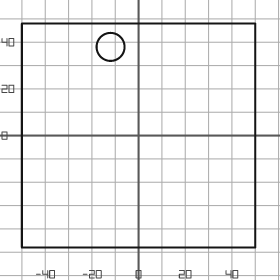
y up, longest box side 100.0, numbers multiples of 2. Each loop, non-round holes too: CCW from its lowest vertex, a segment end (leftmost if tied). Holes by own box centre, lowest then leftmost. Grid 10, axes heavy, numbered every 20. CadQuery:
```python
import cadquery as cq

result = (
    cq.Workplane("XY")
    .moveTo(-50.0, -48.0)
    .lineTo(50.0, -48.0)
    .lineTo(50.0, 48.0)
    .lineTo(-50.0, 48.0)
    .close()
    .moveTo(-12.0, 38.0)
    .circle(6.0)
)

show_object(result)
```